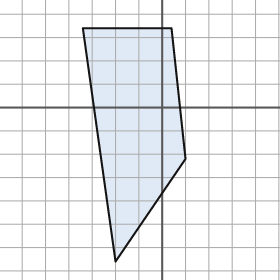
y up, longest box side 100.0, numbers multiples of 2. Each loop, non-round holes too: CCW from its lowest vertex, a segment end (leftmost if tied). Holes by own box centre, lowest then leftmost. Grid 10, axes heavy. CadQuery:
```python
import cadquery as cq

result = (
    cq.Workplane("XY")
    .moveTo(-20.0, -66.0)
    .lineTo(10.0, -22.0)
    .lineTo(4.0, 34.0)
    .lineTo(-34.0, 34.0)
    .close()
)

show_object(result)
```